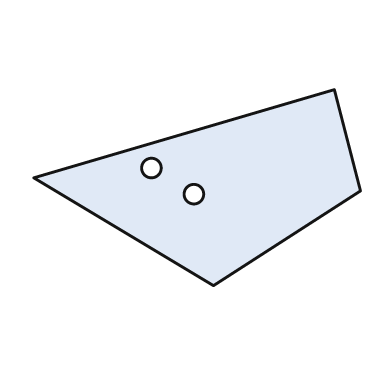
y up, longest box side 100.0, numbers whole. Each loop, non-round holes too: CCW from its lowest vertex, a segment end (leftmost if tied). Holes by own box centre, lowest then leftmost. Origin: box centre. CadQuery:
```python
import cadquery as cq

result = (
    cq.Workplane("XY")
    .moveTo(5.0, -30.0)
    .lineTo(50.0, -1.0)
    .lineTo(42.0, 30.0)
    .lineTo(-50.0, 3.0)
    .close()
    .moveTo(-1.0, -2.0)
    .circle(3.0)
    .moveTo(-14.0, 6.0)
    .circle(3.0)
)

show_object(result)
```